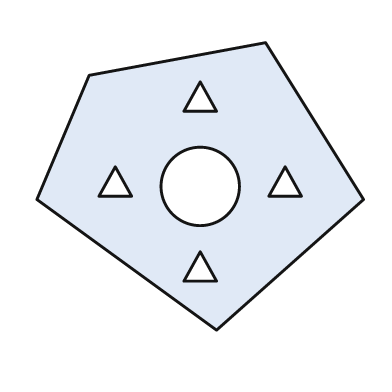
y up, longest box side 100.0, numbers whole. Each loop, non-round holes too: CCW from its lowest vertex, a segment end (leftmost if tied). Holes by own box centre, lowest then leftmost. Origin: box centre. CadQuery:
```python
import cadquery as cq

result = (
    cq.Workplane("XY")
    .moveTo(5.0, -44.0)
    .lineTo(50.0, -4.0)
    .lineTo(20.0, 44.0)
    .lineTo(-34.0, 34.0)
    .lineTo(-50.0, -4.0)
    .close()
    .moveTo(-5.0, -29.0)
    .lineTo(5.0, -29.0)
    .lineTo(0.0, -20.0)
    .close()
    .moveTo(0.0, 0.0)
    .circle(12.0)
    .moveTo(-31.0, -3.0)
    .lineTo(-21.0, -3.0)
    .lineTo(-26.0, 6.0)
    .close()
    .moveTo(21.0, -3.0)
    .lineTo(31.0, -3.0)
    .lineTo(26.0, 6.0)
    .close()
    .moveTo(-5.0, 23.0)
    .lineTo(5.0, 23.0)
    .lineTo(0.0, 32.0)
    .close()
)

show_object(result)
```